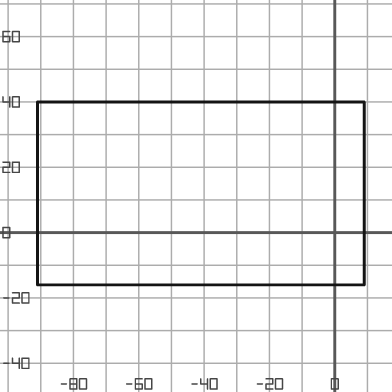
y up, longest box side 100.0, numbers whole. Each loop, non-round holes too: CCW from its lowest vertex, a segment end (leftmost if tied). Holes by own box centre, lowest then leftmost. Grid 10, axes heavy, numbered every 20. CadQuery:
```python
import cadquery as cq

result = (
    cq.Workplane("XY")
    .moveTo(-91.0, -16.0)
    .lineTo(9.0, -16.0)
    .lineTo(9.0, 40.0)
    .lineTo(-91.0, 40.0)
    .close()
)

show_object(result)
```